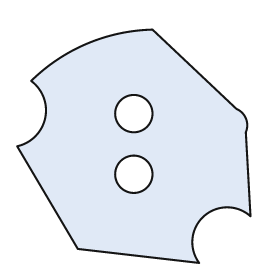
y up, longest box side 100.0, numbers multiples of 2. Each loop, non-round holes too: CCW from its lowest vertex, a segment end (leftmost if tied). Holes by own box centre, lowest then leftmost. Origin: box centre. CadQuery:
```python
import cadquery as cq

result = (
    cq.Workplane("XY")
    .moveTo(28.0, -50.0)
    .threePointArc((30.0, -30.0), (50.0, -30.0))
    .lineTo(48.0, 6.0)
    .threePointArc((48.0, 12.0), (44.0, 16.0))
    .lineTo(8.0, 50.0)
    .threePointArc((-20.0, 44.0), (-44.0, 28.0))
    .threePointArc((-38.0, 12.0), (-50.0, 0.0))
    .lineTo(-24.0, -44.0)
    .close()
    .moveTo(0.0, -12.0)
    .circle(8.0)
    .moveTo(0.0, 14.0)
    .circle(8.0)
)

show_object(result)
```